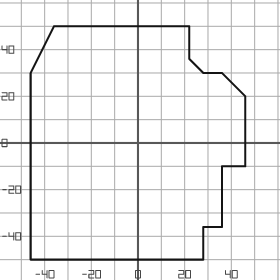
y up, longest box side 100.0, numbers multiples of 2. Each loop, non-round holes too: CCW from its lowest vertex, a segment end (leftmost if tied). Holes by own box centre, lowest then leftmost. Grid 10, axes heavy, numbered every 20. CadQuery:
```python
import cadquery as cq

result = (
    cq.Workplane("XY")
    .moveTo(-46.0, -50.0)
    .lineTo(28.0, -50.0)
    .lineTo(28.0, -36.0)
    .lineTo(36.0, -36.0)
    .lineTo(36.0, -10.0)
    .lineTo(46.0, -10.0)
    .lineTo(46.0, 20.0)
    .lineTo(36.0, 30.0)
    .lineTo(28.0, 30.0)
    .lineTo(22.0, 36.0)
    .lineTo(22.0, 50.0)
    .lineTo(-36.0, 50.0)
    .lineTo(-46.0, 30.0)
    .close()
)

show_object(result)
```